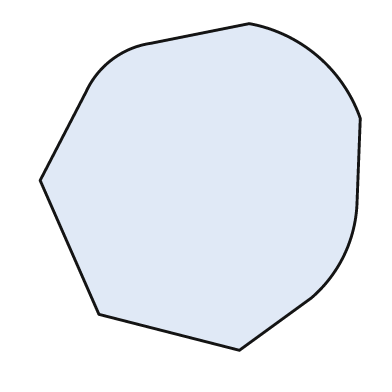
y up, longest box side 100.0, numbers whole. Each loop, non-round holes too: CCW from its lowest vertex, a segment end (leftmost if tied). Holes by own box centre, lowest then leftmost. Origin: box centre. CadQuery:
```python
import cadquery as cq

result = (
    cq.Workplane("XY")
    .moveTo(12.0, -50.0)
    .lineTo(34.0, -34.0)
    .threePointArc((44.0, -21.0), (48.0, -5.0))
    .lineTo(49.0, 21.0)
    .threePointArc((36.0, 40.0), (15.0, 50.0))
    .lineTo(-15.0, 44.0)
    .threePointArc((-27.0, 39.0), (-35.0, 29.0))
    .lineTo(-49.0, 2.0)
    .lineTo(-31.0, -39.0)
    .close()
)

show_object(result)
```